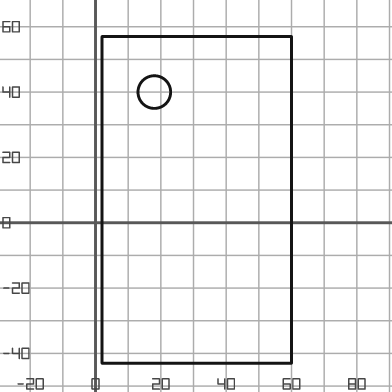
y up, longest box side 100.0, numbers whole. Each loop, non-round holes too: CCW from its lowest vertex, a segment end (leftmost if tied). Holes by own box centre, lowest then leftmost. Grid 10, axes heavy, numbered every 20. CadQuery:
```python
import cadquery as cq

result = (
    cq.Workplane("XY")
    .moveTo(2.0, -43.0)
    .lineTo(60.0, -43.0)
    .lineTo(60.0, 57.0)
    .lineTo(2.0, 57.0)
    .close()
    .moveTo(18.0, 40.0)
    .circle(5.0)
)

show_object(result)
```